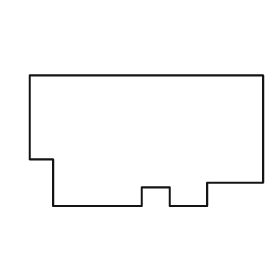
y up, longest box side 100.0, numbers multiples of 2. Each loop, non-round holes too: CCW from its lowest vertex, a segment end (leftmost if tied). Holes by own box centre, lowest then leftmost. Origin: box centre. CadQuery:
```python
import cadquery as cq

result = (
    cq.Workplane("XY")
    .moveTo(-40.0, -28.0)
    .lineTo(-2.0, -28.0)
    .lineTo(-2.0, -20.0)
    .lineTo(10.0, -20.0)
    .lineTo(10.0, -28.0)
    .lineTo(26.0, -28.0)
    .lineTo(26.0, -18.0)
    .lineTo(50.0, -18.0)
    .lineTo(50.0, 28.0)
    .lineTo(-50.0, 28.0)
    .lineTo(-50.0, -8.0)
    .lineTo(-40.0, -8.0)
    .close()
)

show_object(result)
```